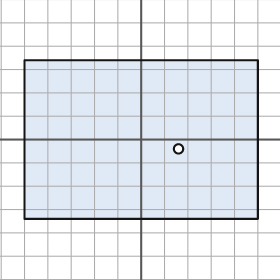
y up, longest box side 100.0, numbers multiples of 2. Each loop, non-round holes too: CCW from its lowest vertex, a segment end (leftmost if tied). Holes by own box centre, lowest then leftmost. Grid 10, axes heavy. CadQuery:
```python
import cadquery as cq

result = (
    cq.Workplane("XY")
    .moveTo(-50.0, -34.0)
    .lineTo(50.0, -34.0)
    .lineTo(50.0, 34.0)
    .lineTo(-50.0, 34.0)
    .close()
    .moveTo(16.0, -4.0)
    .circle(2.0)
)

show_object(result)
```